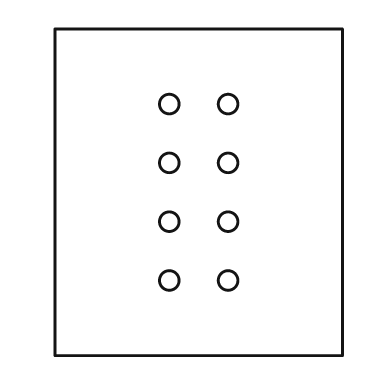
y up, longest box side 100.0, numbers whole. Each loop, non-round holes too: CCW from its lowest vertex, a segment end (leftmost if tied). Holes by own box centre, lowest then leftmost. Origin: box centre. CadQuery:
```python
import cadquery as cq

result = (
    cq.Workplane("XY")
    .moveTo(-44.0, -50.0)
    .lineTo(44.0, -50.0)
    .lineTo(44.0, 50.0)
    .lineTo(-44.0, 50.0)
    .close()
    .moveTo(-9.0, -27.0)
    .circle(3.0)
    .moveTo(9.0, -27.0)
    .circle(3.0)
    .moveTo(-9.0, -9.0)
    .circle(3.0)
    .moveTo(9.0, -9.0)
    .circle(3.0)
    .moveTo(-9.0, 9.0)
    .circle(3.0)
    .moveTo(9.0, 9.0)
    .circle(3.0)
    .moveTo(-9.0, 27.0)
    .circle(3.0)
    .moveTo(9.0, 27.0)
    .circle(3.0)
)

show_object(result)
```